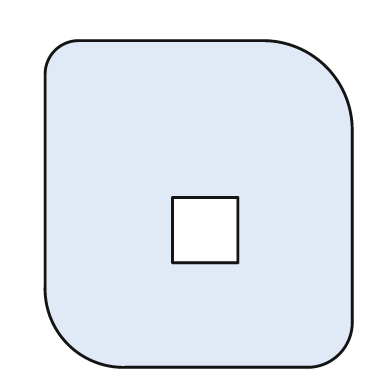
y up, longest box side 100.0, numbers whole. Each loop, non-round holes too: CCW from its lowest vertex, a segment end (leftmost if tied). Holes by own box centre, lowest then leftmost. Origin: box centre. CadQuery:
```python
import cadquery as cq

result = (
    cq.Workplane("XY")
    .moveTo(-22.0, -50.0)
    .lineTo(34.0, -50.0)
    .threePointArc((43.0, -46.0), (47.0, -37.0))
    .lineTo(47.0, 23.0)
    .threePointArc((39.0, 42.0), (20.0, 50.0))
    .lineTo(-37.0, 50.0)
    .threePointArc((-44.0, 47.0), (-47.0, 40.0))
    .lineTo(-47.0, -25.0)
    .threePointArc((-40.0, -43.0), (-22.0, -50.0))
    .close()
    .moveTo(-8.0, -18.0)
    .lineTo(12.0, -18.0)
    .lineTo(12.0, 2.0)
    .lineTo(-8.0, 2.0)
    .close()
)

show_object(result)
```